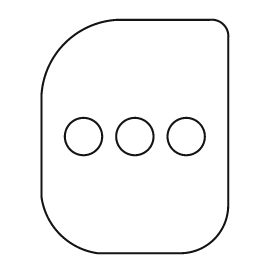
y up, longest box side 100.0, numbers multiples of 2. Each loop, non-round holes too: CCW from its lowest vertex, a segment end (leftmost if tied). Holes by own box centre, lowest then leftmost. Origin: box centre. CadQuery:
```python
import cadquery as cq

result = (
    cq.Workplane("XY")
    .moveTo(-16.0, -50.0)
    .lineTo(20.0, -50.0)
    .threePointArc((34.0, -44.0), (40.0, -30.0))
    .lineTo(40.0, 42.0)
    .threePointArc((38.0, 48.0), (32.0, 50.0))
    .lineTo(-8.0, 50.0)
    .threePointArc((-30.0, 40.0), (-40.0, 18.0))
    .lineTo(-40.0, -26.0)
    .threePointArc((-32.0, -42.0), (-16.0, -50.0))
    .close()
    .moveTo(-22.0, 0.0)
    .circle(8.0)
    .moveTo(0.0, 0.0)
    .circle(8.0)
    .moveTo(22.0, 0.0)
    .circle(8.0)
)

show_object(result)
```